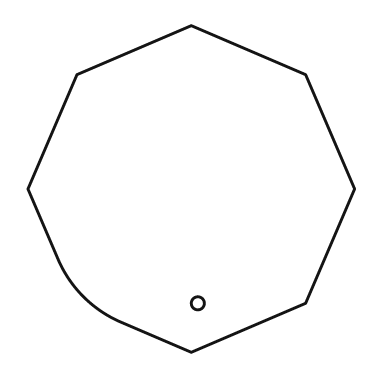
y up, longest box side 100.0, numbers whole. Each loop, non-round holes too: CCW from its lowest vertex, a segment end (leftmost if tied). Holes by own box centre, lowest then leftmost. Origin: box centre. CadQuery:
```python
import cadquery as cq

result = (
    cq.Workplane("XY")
    .moveTo(0.0, -50.0)
    .lineTo(35.0, -35.0)
    .lineTo(50.0, 0.0)
    .lineTo(35.0, 35.0)
    .lineTo(0.0, 50.0)
    .lineTo(-35.0, 35.0)
    .lineTo(-50.0, 0.0)
    .lineTo(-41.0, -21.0)
    .threePointArc((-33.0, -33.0), (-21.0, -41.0))
    .close()
    .moveTo(2.0, -35.0)
    .circle(2.0)
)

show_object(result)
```